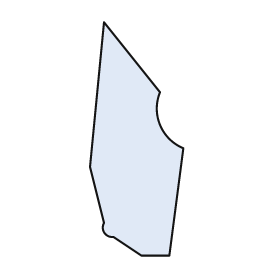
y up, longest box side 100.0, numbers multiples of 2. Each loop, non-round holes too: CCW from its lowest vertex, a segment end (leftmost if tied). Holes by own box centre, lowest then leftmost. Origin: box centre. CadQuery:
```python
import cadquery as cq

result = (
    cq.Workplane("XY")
    .moveTo(2.0, -50.0)
    .lineTo(14.0, -50.0)
    .lineTo(20.0, -4.0)
    .threePointArc((10.0, 6.0), (10.0, 20.0))
    .lineTo(-14.0, 50.0)
    .lineTo(-20.0, -12.0)
    .lineTo(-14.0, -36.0)
    .threePointArc((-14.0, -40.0), (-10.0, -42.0))
    .close()
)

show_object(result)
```